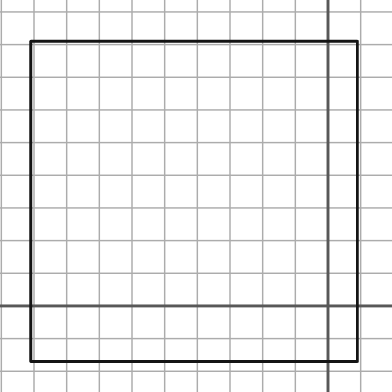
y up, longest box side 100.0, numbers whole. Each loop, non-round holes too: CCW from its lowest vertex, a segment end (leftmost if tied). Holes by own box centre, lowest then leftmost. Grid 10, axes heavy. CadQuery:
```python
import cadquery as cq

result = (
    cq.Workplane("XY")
    .moveTo(-91.0, -17.0)
    .lineTo(9.0, -17.0)
    .lineTo(9.0, 81.0)
    .lineTo(-91.0, 81.0)
    .close()
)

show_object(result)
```